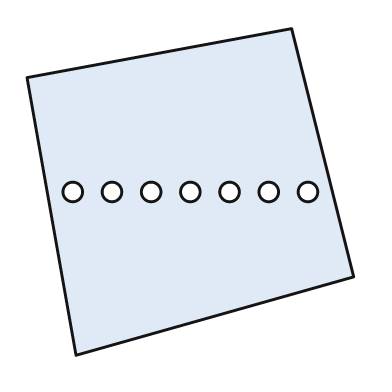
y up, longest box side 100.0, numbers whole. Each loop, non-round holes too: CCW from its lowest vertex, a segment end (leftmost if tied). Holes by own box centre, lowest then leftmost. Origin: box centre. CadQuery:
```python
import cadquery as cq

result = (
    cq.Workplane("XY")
    .moveTo(-35.0, -50.0)
    .lineTo(50.0, -26.0)
    .lineTo(31.0, 50.0)
    .lineTo(-50.0, 35.0)
    .close()
    .moveTo(-36.0, 0.0)
    .circle(3.0)
    .moveTo(-24.0, 0.0)
    .circle(3.0)
    .moveTo(-12.0, 0.0)
    .circle(3.0)
    .moveTo(0.0, 0.0)
    .circle(3.0)
    .moveTo(12.0, 0.0)
    .circle(3.0)
    .moveTo(24.0, 0.0)
    .circle(3.0)
    .moveTo(36.0, 0.0)
    .circle(3.0)
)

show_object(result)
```